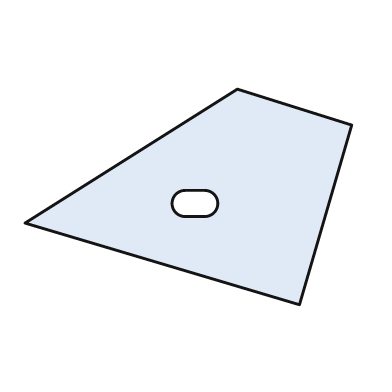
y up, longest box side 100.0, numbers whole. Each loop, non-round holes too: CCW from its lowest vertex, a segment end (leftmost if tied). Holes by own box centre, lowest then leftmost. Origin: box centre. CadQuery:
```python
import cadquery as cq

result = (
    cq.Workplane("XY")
    .moveTo(34.0, -33.0)
    .lineTo(50.0, 22.0)
    .lineTo(15.0, 33.0)
    .lineTo(-50.0, -8.0)
    .close()
    .moveTo(-1.0, -6.0)
    .lineTo(5.0, -6.0)
    .threePointArc((9.0, -2.0), (5.0, 2.0))
    .lineTo(-1.0, 2.0)
    .threePointArc((-5.0, -2.0), (-1.0, -6.0))
    .close()
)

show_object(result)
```